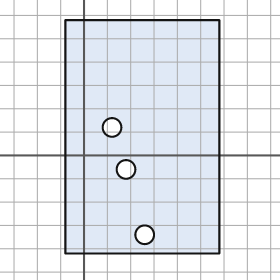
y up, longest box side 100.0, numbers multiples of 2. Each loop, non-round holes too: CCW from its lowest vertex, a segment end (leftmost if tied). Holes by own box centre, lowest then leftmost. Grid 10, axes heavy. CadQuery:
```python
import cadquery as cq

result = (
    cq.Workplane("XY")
    .moveTo(-8.0, -42.0)
    .lineTo(58.0, -42.0)
    .lineTo(58.0, 58.0)
    .lineTo(-8.0, 58.0)
    .close()
    .moveTo(26.0, -34.0)
    .circle(4.0)
    .moveTo(18.0, -6.0)
    .circle(4.0)
    .moveTo(12.0, 12.0)
    .circle(4.0)
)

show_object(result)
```